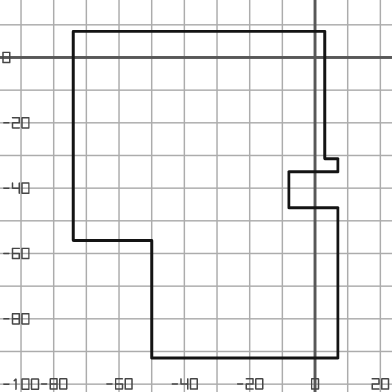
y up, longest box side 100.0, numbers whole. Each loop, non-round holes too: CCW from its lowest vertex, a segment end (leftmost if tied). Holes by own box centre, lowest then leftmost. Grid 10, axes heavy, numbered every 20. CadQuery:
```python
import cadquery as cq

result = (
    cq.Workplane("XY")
    .moveTo(-50.0, -92.0)
    .lineTo(7.0, -92.0)
    .lineTo(7.0, -46.0)
    .lineTo(-8.0, -46.0)
    .lineTo(-8.0, -35.0)
    .lineTo(7.0, -35.0)
    .lineTo(7.0, -31.0)
    .lineTo(3.0, -31.0)
    .lineTo(3.0, 8.0)
    .lineTo(-74.0, 8.0)
    .lineTo(-74.0, -56.0)
    .lineTo(-50.0, -56.0)
    .close()
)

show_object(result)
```